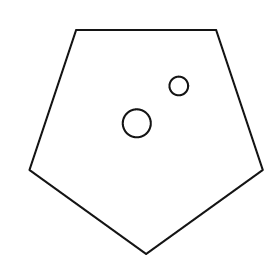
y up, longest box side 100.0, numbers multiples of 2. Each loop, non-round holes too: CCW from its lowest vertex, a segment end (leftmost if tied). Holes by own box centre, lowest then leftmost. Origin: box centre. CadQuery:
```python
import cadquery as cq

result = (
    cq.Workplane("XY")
    .moveTo(0.0, -48.0)
    .lineTo(50.0, -12.0)
    .lineTo(30.0, 48.0)
    .lineTo(-30.0, 48.0)
    .lineTo(-50.0, -12.0)
    .close()
    .moveTo(-4.0, 8.0)
    .circle(6.0)
    .moveTo(14.0, 24.0)
    .circle(4.0)
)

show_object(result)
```